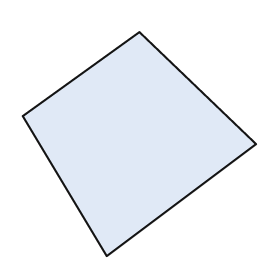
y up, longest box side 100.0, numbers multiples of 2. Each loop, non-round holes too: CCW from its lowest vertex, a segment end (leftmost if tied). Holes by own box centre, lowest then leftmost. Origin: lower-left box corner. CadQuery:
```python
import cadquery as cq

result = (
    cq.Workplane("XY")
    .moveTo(36.0, 0.0)
    .lineTo(100.0, 48.0)
    .lineTo(50.0, 96.0)
    .lineTo(0.0, 60.0)
    .close()
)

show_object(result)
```